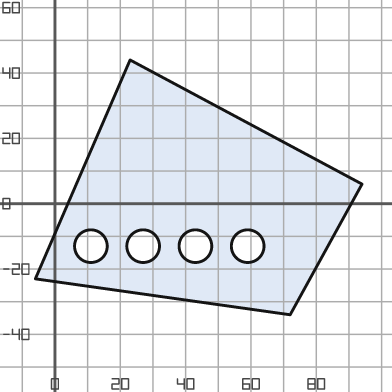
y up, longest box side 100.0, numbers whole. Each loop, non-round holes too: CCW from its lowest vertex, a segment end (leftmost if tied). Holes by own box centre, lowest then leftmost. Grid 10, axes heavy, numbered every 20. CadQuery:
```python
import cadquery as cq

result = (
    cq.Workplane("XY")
    .moveTo(72.0, -34.0)
    .lineTo(94.0, 6.0)
    .lineTo(23.0, 44.0)
    .lineTo(-6.0, -23.0)
    .close()
    .moveTo(11.0, -13.0)
    .circle(5.0)
    .moveTo(27.0, -13.0)
    .circle(5.0)
    .moveTo(43.0, -13.0)
    .circle(5.0)
    .moveTo(59.0, -13.0)
    .circle(5.0)
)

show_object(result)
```